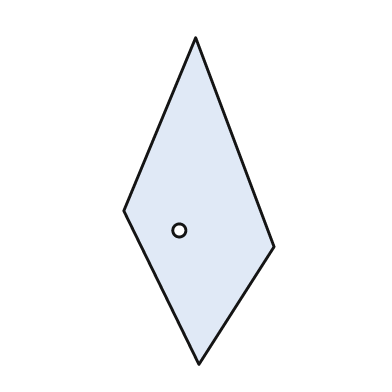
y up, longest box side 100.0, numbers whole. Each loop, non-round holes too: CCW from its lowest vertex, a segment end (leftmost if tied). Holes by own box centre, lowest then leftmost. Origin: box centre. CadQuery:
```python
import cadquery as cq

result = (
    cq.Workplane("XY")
    .moveTo(0.0, -50.0)
    .lineTo(23.0, -14.0)
    .lineTo(-1.0, 50.0)
    .lineTo(-23.0, -3.0)
    .close()
    .moveTo(-6.0, -9.0)
    .circle(2.0)
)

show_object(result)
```